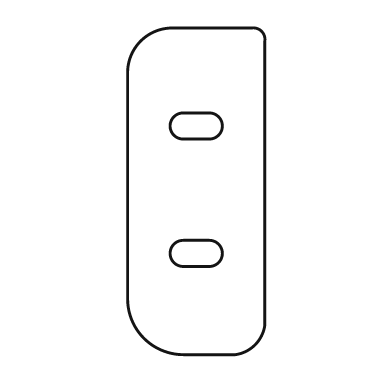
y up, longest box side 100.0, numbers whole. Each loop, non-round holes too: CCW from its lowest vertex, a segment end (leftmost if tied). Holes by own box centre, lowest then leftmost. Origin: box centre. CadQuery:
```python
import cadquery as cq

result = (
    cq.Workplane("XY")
    .moveTo(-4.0, -50.0)
    .lineTo(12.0, -50.0)
    .threePointArc((18.0, -47.0), (21.0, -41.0))
    .lineTo(21.0, 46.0)
    .threePointArc((20.0, 49.0), (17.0, 50.0))
    .lineTo(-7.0, 50.0)
    .threePointArc((-17.0, 46.0), (-21.0, 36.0))
    .lineTo(-21.0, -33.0)
    .threePointArc((-16.0, -45.0), (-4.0, -50.0))
    .close()
    .moveTo(-4.0, -23.0)
    .lineTo(4.0, -23.0)
    .threePointArc((8.0, -19.0), (4.0, -15.0))
    .lineTo(-4.0, -15.0)
    .threePointArc((-8.0, -19.0), (-4.0, -23.0))
    .close()
    .moveTo(-4.0, 16.0)
    .lineTo(4.0, 16.0)
    .threePointArc((8.0, 20.0), (4.0, 24.0))
    .lineTo(-4.0, 24.0)
    .threePointArc((-8.0, 20.0), (-4.0, 16.0))
    .close()
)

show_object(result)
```